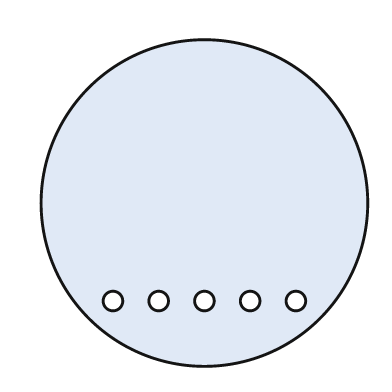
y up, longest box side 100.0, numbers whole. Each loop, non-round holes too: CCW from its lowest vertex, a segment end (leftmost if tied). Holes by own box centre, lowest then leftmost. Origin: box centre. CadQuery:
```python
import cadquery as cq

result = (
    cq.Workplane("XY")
    .moveTo(0.0, 0.0)
    .circle(50.0)
    .moveTo(-28.0, -30.0)
    .circle(3.0)
    .moveTo(-14.0, -30.0)
    .circle(3.0)
    .moveTo(0.0, -30.0)
    .circle(3.0)
    .moveTo(14.0, -30.0)
    .circle(3.0)
    .moveTo(28.0, -30.0)
    .circle(3.0)
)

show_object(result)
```